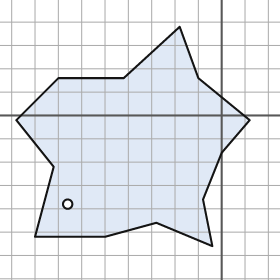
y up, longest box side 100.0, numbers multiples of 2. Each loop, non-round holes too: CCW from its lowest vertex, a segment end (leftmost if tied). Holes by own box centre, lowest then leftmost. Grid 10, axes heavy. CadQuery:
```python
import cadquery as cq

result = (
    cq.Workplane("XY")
    .moveTo(-4.0, -56.0)
    .lineTo(-8.0, -36.0)
    .lineTo(0.0, -16.0)
    .lineTo(12.0, -2.0)
    .lineTo(-10.0, 16.0)
    .lineTo(-18.0, 38.0)
    .lineTo(-42.0, 16.0)
    .lineTo(-70.0, 16.0)
    .lineTo(-88.0, -2.0)
    .lineTo(-72.0, -22.0)
    .lineTo(-80.0, -52.0)
    .lineTo(-50.0, -52.0)
    .lineTo(-28.0, -46.0)
    .close()
    .moveTo(-66.0, -38.0)
    .circle(2.0)
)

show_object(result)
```